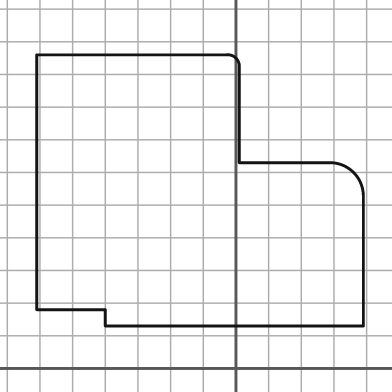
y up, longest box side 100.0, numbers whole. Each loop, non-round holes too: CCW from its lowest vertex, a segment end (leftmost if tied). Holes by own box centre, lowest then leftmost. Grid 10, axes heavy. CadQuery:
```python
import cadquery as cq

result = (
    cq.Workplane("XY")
    .moveTo(-40.0, 13.0)
    .lineTo(39.0, 13.0)
    .lineTo(39.0, 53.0)
    .threePointArc((36.0, 60.0), (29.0, 63.0))
    .lineTo(1.0, 63.0)
    .lineTo(1.0, 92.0)
    .threePointArc((0.0, 95.0), (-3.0, 96.0))
    .lineTo(-61.0, 96.0)
    .lineTo(-61.0, 18.0)
    .lineTo(-40.0, 18.0)
    .close()
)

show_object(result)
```